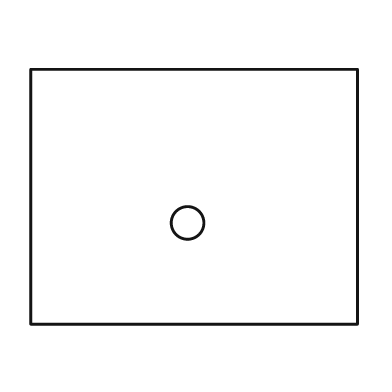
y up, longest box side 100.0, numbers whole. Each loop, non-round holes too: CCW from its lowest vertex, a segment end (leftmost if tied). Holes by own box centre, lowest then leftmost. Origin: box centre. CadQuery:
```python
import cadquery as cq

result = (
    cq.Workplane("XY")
    .moveTo(-50.0, -39.0)
    .lineTo(50.0, -39.0)
    .lineTo(50.0, 39.0)
    .lineTo(-50.0, 39.0)
    .close()
    .moveTo(-2.0, -8.0)
    .circle(5.0)
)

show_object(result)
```